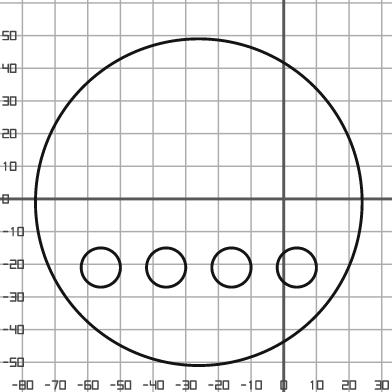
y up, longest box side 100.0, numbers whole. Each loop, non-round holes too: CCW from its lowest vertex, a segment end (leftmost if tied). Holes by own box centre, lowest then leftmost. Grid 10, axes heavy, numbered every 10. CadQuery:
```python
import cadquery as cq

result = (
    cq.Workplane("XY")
    .moveTo(-26.0, -1.0)
    .circle(50.0)
    .moveTo(-56.0, -21.0)
    .circle(6.0)
    .moveTo(-36.0, -21.0)
    .circle(6.0)
    .moveTo(-16.0, -21.0)
    .circle(6.0)
    .moveTo(4.0, -21.0)
    .circle(6.0)
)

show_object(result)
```